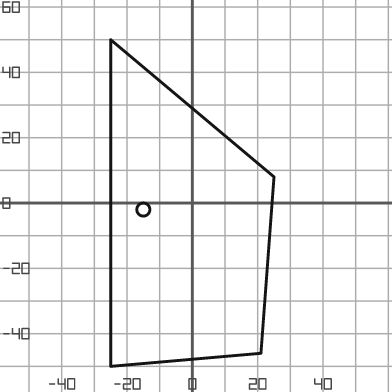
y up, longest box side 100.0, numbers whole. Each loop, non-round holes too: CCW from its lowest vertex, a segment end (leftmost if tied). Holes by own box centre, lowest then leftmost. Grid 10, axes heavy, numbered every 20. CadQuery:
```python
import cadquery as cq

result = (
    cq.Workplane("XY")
    .moveTo(-25.0, -50.0)
    .lineTo(21.0, -46.0)
    .lineTo(25.0, 8.0)
    .lineTo(-25.0, 50.0)
    .close()
    .moveTo(-15.0, -2.0)
    .circle(2.0)
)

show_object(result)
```